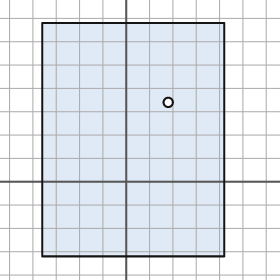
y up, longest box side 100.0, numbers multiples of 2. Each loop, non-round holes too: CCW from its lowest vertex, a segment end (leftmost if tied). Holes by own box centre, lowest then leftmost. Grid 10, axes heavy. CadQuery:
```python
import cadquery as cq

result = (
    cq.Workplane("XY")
    .moveTo(-36.0, -32.0)
    .lineTo(42.0, -32.0)
    .lineTo(42.0, 68.0)
    .lineTo(-36.0, 68.0)
    .close()
    .moveTo(18.0, 34.0)
    .circle(2.0)
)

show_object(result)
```